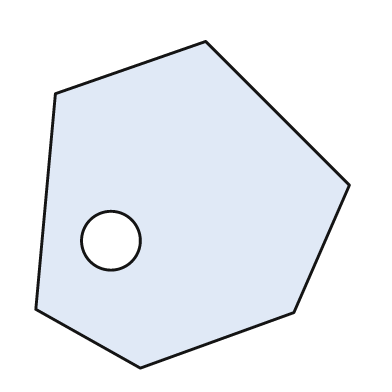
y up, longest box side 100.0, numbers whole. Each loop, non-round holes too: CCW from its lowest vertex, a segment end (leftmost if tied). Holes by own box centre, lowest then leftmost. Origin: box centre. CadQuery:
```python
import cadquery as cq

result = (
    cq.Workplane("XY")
    .moveTo(-16.0, -50.0)
    .lineTo(31.0, -33.0)
    .lineTo(48.0, 6.0)
    .lineTo(4.0, 50.0)
    .lineTo(-42.0, 34.0)
    .lineTo(-48.0, -32.0)
    .close()
    .moveTo(-25.0, -11.0)
    .circle(9.0)
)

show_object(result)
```